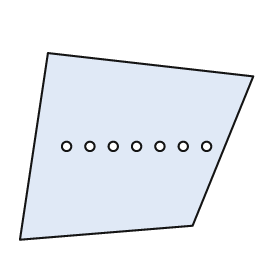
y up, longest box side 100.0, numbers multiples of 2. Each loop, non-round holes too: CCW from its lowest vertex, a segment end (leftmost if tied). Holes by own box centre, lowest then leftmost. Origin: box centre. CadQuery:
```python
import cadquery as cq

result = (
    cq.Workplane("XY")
    .moveTo(-50.0, -40.0)
    .lineTo(24.0, -34.0)
    .lineTo(50.0, 30.0)
    .lineTo(-38.0, 40.0)
    .close()
    .moveTo(-30.0, 0.0)
    .circle(2.0)
    .moveTo(-20.0, 0.0)
    .circle(2.0)
    .moveTo(-10.0, 0.0)
    .circle(2.0)
    .moveTo(0.0, 0.0)
    .circle(2.0)
    .moveTo(10.0, 0.0)
    .circle(2.0)
    .moveTo(20.0, 0.0)
    .circle(2.0)
    .moveTo(30.0, 0.0)
    .circle(2.0)
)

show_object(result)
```